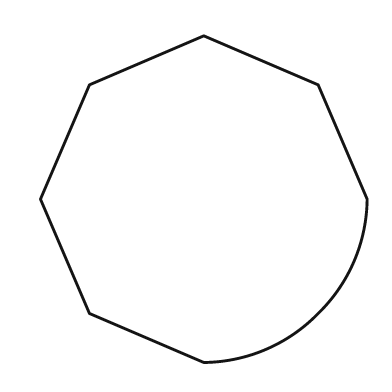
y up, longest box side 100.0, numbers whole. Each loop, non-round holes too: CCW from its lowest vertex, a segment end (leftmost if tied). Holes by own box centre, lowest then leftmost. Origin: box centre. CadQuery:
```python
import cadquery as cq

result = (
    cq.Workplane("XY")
    .moveTo(0.0, -50.0)
    .threePointArc((19.0, -46.0), (35.0, -35.0))
    .threePointArc((46.0, -19.0), (50.0, 0.0))
    .lineTo(35.0, 35.0)
    .lineTo(0.0, 50.0)
    .lineTo(-35.0, 35.0)
    .lineTo(-50.0, 0.0)
    .lineTo(-35.0, -35.0)
    .close()
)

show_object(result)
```